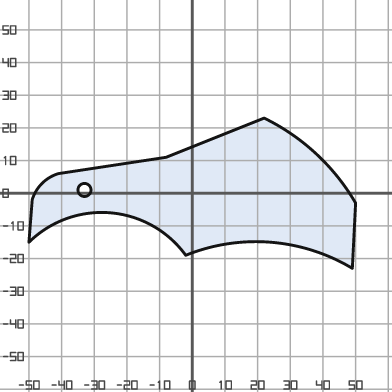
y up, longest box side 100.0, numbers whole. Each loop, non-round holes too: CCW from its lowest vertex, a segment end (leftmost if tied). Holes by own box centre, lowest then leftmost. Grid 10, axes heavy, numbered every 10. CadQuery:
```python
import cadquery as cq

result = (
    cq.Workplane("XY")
    .moveTo(49.0, -23.0)
    .lineTo(50.0, -3.0)
    .threePointArc((38.0, 12.0), (22.0, 23.0))
    .lineTo(-8.0, 11.0)
    .lineTo(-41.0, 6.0)
    .threePointArc((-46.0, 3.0), (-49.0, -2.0))
    .lineTo(-50.0, -15.0)
    .threePointArc((-25.0, -6.0), (-2.0, -19.0))
    .threePointArc((24.0, -15.0), (49.0, -23.0))
    .close()
    .moveTo(-33.0, 1.0)
    .circle(2.0)
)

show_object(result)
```